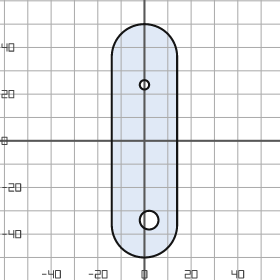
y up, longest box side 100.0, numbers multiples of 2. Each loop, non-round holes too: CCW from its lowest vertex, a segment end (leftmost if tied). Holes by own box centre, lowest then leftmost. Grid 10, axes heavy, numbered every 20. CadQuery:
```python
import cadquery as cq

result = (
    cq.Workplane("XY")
    .moveTo(-14.0, -36.0)
    .threePointArc((0.0, -50.0), (14.0, -36.0))
    .lineTo(14.0, 36.0)
    .threePointArc((0.0, 50.0), (-14.0, 36.0))
    .close()
    .moveTo(2.0, -34.0)
    .circle(4.0)
    .moveTo(0.0, 24.0)
    .circle(2.0)
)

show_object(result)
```